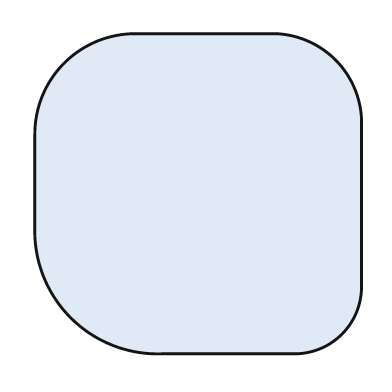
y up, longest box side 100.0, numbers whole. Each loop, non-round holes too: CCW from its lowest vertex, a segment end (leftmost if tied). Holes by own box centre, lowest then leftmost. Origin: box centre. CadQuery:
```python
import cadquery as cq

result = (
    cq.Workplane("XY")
    .moveTo(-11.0, -49.0)
    .lineTo(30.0, -49.0)
    .threePointArc((44.0, -43.0), (50.0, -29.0))
    .lineTo(50.0, 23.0)
    .threePointArc((42.0, 41.0), (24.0, 49.0))
    .lineTo(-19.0, 49.0)
    .threePointArc((-41.0, 40.0), (-50.0, 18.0))
    .lineTo(-50.0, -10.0)
    .threePointArc((-39.0, -38.0), (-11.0, -49.0))
    .close()
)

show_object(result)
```